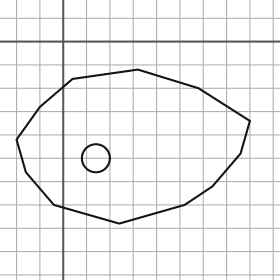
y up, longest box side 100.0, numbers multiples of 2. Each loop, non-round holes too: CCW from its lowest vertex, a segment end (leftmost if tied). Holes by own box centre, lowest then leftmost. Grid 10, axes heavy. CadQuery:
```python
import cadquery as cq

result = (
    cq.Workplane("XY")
    .moveTo(24.0, -78.0)
    .lineTo(52.0, -70.0)
    .lineTo(64.0, -62.0)
    .lineTo(76.0, -48.0)
    .lineTo(80.0, -34.0)
    .lineTo(58.0, -20.0)
    .lineTo(32.0, -12.0)
    .lineTo(4.0, -16.0)
    .lineTo(-10.0, -28.0)
    .lineTo(-20.0, -42.0)
    .lineTo(-16.0, -56.0)
    .lineTo(-4.0, -70.0)
    .close()
    .moveTo(14.0, -50.0)
    .circle(6.0)
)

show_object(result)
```